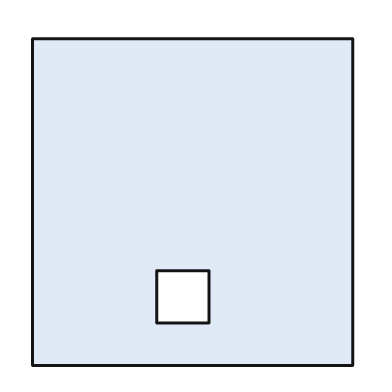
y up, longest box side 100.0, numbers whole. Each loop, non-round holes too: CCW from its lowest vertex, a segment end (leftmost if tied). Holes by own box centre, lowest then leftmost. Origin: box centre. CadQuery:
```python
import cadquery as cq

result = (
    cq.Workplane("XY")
    .moveTo(-49.0, -50.0)
    .lineTo(49.0, -50.0)
    .lineTo(49.0, 50.0)
    .lineTo(-49.0, 50.0)
    .close()
    .moveTo(-11.0, -37.0)
    .lineTo(5.0, -37.0)
    .lineTo(5.0, -21.0)
    .lineTo(-11.0, -21.0)
    .close()
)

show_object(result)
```